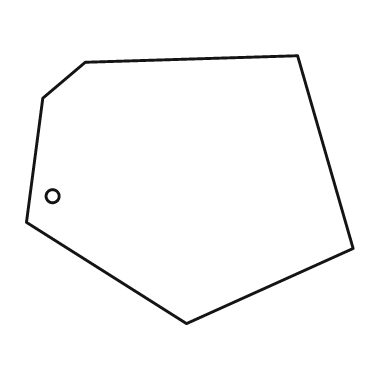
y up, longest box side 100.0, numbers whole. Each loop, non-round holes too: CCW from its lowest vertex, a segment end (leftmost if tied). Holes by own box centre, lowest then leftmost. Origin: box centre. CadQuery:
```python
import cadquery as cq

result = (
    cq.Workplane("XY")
    .moveTo(-1.0, -41.0)
    .lineTo(50.0, -18.0)
    .lineTo(33.0, 41.0)
    .lineTo(-32.0, 39.0)
    .lineTo(-45.0, 28.0)
    .lineTo(-50.0, -10.0)
    .close()
    .moveTo(-42.0, -2.0)
    .circle(2.0)
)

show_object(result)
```